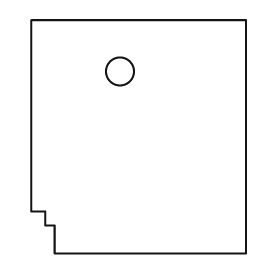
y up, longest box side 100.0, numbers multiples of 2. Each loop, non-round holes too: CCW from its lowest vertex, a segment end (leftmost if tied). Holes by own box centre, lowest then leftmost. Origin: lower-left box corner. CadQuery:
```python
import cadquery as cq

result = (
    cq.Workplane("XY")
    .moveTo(10.0, 0.0)
    .lineTo(92.0, 0.0)
    .lineTo(92.0, 100.0)
    .lineTo(0.0, 100.0)
    .lineTo(0.0, 18.0)
    .lineTo(6.0, 18.0)
    .lineTo(6.0, 12.0)
    .lineTo(10.0, 12.0)
    .close()
    .moveTo(38.0, 78.0)
    .circle(6.0)
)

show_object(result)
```